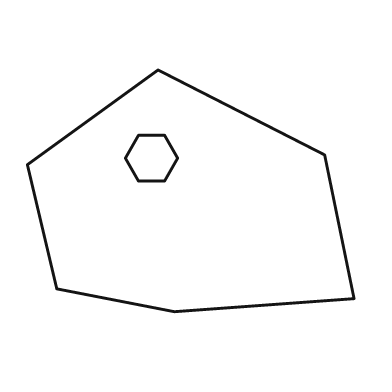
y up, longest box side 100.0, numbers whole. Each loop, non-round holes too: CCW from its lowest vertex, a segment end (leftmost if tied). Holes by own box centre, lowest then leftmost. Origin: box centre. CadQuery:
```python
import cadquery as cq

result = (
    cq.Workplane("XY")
    .moveTo(-5.0, -37.0)
    .lineTo(50.0, -33.0)
    .lineTo(41.0, 11.0)
    .lineTo(-10.0, 37.0)
    .lineTo(-50.0, 8.0)
    .lineTo(-41.0, -30.0)
    .close()
    .moveTo(-16.0, 3.0)
    .lineTo(-8.0, 3.0)
    .lineTo(-4.0, 10.0)
    .lineTo(-8.0, 17.0)
    .lineTo(-16.0, 17.0)
    .lineTo(-20.0, 10.0)
    .close()
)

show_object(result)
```